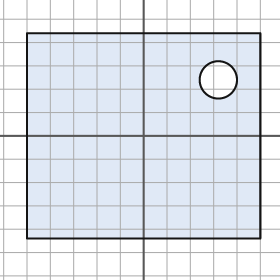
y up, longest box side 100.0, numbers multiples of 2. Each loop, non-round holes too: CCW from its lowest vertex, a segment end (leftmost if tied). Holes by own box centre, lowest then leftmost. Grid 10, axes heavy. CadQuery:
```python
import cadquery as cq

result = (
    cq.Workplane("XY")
    .moveTo(-50.0, -44.0)
    .lineTo(50.0, -44.0)
    .lineTo(50.0, 44.0)
    .lineTo(-50.0, 44.0)
    .close()
    .moveTo(32.0, 24.0)
    .circle(8.0)
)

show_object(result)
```